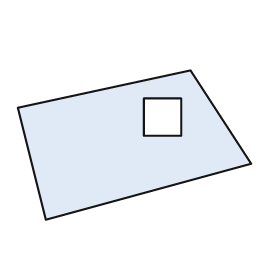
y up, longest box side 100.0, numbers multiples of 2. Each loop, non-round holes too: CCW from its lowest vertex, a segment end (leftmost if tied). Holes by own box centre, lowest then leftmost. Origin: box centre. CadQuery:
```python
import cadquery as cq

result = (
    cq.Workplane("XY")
    .moveTo(-38.0, -32.0)
    .lineTo(50.0, -8.0)
    .lineTo(24.0, 32.0)
    .lineTo(-50.0, 16.0)
    .close()
    .moveTo(4.0, 4.0)
    .lineTo(20.0, 4.0)
    .lineTo(20.0, 20.0)
    .lineTo(4.0, 20.0)
    .close()
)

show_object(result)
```